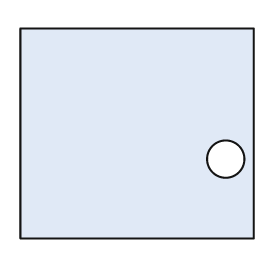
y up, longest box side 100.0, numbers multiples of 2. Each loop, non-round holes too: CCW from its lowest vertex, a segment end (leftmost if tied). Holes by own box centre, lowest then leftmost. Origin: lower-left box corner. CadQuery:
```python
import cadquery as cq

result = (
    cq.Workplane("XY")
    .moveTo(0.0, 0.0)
    .lineTo(100.0, 0.0)
    .lineTo(100.0, 90.0)
    .lineTo(0.0, 90.0)
    .close()
    .moveTo(88.0, 34.0)
    .circle(8.0)
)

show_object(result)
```